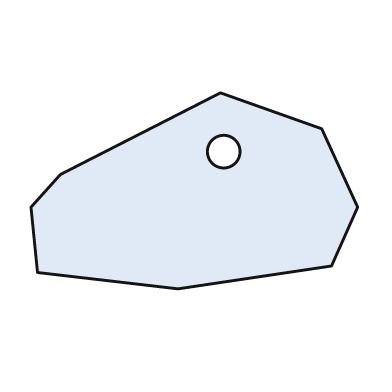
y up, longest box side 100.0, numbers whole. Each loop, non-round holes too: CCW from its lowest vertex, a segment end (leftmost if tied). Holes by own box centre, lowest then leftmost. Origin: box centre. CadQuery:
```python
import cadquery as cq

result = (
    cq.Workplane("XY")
    .moveTo(-5.0, -30.0)
    .lineTo(42.0, -23.0)
    .lineTo(50.0, -5.0)
    .lineTo(39.0, 19.0)
    .lineTo(8.0, 30.0)
    .lineTo(-41.0, 5.0)
    .lineTo(-50.0, -5.0)
    .lineTo(-48.0, -25.0)
    .close()
    .moveTo(9.0, 12.0)
    .circle(5.0)
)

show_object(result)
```